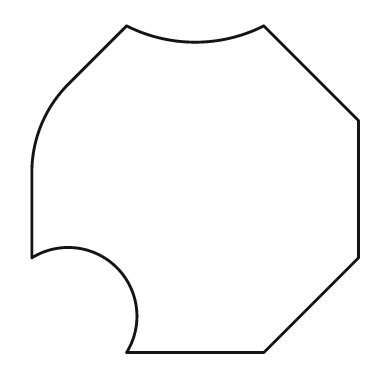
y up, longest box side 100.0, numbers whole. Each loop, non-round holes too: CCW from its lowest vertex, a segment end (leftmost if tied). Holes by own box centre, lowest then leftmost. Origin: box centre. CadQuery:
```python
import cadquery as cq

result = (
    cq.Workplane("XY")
    .moveTo(-21.0, -50.0)
    .lineTo(21.0, -50.0)
    .lineTo(50.0, -21.0)
    .lineTo(50.0, 21.0)
    .lineTo(21.0, 50.0)
    .threePointArc((0.0, 45.0), (-21.0, 50.0))
    .lineTo(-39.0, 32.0)
    .threePointArc((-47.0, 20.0), (-50.0, 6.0))
    .lineTo(-50.0, -21.0)
    .threePointArc((-24.0, -24.0), (-21.0, -50.0))
    .close()
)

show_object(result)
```